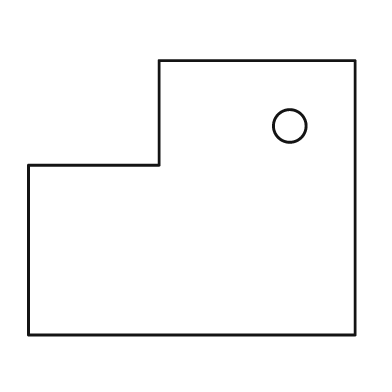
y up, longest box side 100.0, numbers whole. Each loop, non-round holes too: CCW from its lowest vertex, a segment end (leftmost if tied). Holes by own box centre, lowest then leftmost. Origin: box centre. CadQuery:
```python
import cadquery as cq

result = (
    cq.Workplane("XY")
    .moveTo(-50.0, -42.0)
    .lineTo(50.0, -42.0)
    .lineTo(50.0, 42.0)
    .lineTo(-10.0, 42.0)
    .lineTo(-10.0, 10.0)
    .lineTo(-50.0, 10.0)
    .close()
    .moveTo(30.0, 22.0)
    .circle(5.0)
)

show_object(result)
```